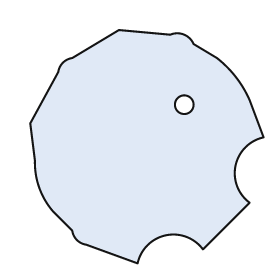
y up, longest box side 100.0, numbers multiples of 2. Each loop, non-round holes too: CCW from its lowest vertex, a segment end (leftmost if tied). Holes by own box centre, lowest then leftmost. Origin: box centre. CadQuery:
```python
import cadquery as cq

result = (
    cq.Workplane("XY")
    .moveTo(-4.0, -50.0)
    .threePointArc((8.0, -38.0), (24.0, -44.0))
    .lineTo(44.0, -24.0)
    .threePointArc((38.0, -8.0), (50.0, 4.0))
    .lineTo(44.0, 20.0)
    .threePointArc((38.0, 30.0), (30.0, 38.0))
    .lineTo(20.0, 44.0)
    .threePointArc((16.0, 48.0), (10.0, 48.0))
    .lineTo(-12.0, 50.0)
    .lineTo(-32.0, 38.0)
    .threePointArc((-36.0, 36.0), (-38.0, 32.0))
    .lineTo(-50.0, 10.0)
    .lineTo(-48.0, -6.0)
    .threePointArc((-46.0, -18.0), (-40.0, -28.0))
    .lineTo(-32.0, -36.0)
    .threePointArc((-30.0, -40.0), (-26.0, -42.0))
    .close()
    .moveTo(16.0, 18.0)
    .circle(4.0)
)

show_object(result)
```